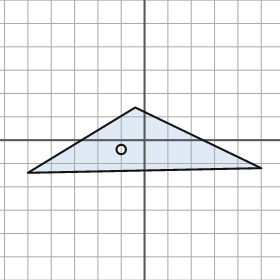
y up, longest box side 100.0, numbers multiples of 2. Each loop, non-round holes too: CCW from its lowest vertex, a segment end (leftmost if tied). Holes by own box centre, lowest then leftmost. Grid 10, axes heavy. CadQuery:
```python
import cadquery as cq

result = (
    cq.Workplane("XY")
    .moveTo(-50.0, -14.0)
    .lineTo(50.0, -12.0)
    .lineTo(-4.0, 14.0)
    .close()
    .moveTo(-10.0, -4.0)
    .circle(2.0)
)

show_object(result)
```